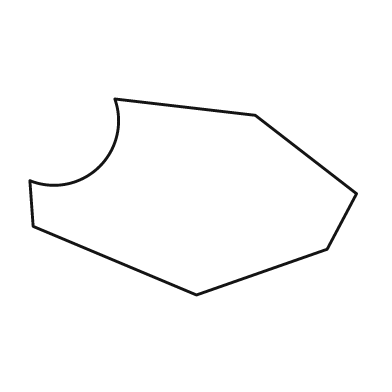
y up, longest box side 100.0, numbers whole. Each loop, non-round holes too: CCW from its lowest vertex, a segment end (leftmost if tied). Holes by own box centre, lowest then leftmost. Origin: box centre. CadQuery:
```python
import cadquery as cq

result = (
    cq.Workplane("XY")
    .moveTo(1.0, -30.0)
    .lineTo(41.0, -16.0)
    .lineTo(50.0, 1.0)
    .lineTo(19.0, 25.0)
    .lineTo(-24.0, 30.0)
    .threePointArc((-29.0, 9.0), (-50.0, 5.0))
    .lineTo(-49.0, -9.0)
    .close()
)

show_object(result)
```